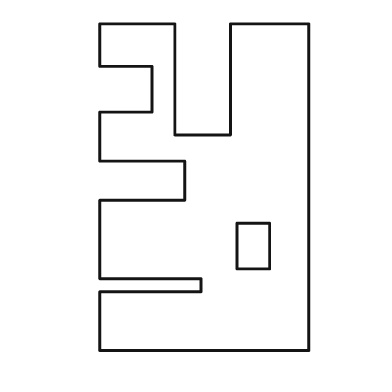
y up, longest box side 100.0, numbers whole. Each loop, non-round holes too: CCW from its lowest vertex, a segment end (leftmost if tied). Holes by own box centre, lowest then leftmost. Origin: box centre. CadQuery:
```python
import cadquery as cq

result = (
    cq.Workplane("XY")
    .moveTo(-32.0, -50.0)
    .lineTo(32.0, -50.0)
    .lineTo(32.0, 50.0)
    .lineTo(8.0, 50.0)
    .lineTo(8.0, 16.0)
    .lineTo(-9.0, 16.0)
    .lineTo(-9.0, 50.0)
    .lineTo(-32.0, 50.0)
    .lineTo(-32.0, 37.0)
    .lineTo(-16.0, 37.0)
    .lineTo(-16.0, 23.0)
    .lineTo(-32.0, 23.0)
    .lineTo(-32.0, 8.0)
    .lineTo(-6.0, 8.0)
    .lineTo(-6.0, -4.0)
    .lineTo(-32.0, -4.0)
    .lineTo(-32.0, -28.0)
    .lineTo(-1.0, -28.0)
    .lineTo(-1.0, -32.0)
    .lineTo(-32.0, -32.0)
    .close()
    .moveTo(10.0, -25.0)
    .lineTo(20.0, -25.0)
    .lineTo(20.0, -11.0)
    .lineTo(10.0, -11.0)
    .close()
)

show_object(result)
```